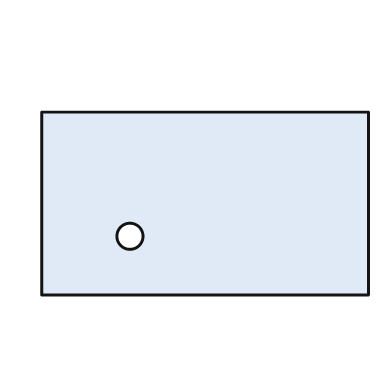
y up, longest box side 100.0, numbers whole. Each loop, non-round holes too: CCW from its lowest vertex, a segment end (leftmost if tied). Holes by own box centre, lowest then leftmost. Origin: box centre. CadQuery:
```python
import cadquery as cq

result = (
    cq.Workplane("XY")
    .moveTo(-50.0, -28.0)
    .lineTo(50.0, -28.0)
    .lineTo(50.0, 28.0)
    .lineTo(-50.0, 28.0)
    .close()
    .moveTo(-23.0, -10.0)
    .circle(4.0)
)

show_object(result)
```